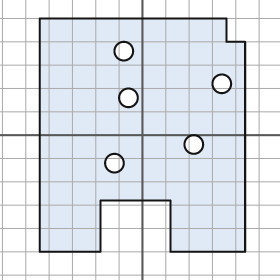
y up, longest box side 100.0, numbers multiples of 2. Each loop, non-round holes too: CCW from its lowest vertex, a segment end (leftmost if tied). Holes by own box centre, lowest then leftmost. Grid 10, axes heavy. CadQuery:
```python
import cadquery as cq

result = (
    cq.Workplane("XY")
    .moveTo(-44.0, -50.0)
    .lineTo(-18.0, -50.0)
    .lineTo(-18.0, -28.0)
    .lineTo(12.0, -28.0)
    .lineTo(12.0, -50.0)
    .lineTo(44.0, -50.0)
    .lineTo(44.0, 40.0)
    .lineTo(36.0, 40.0)
    .lineTo(36.0, 50.0)
    .lineTo(-44.0, 50.0)
    .close()
    .moveTo(-12.0, -12.0)
    .circle(4.0)
    .moveTo(22.0, -4.0)
    .circle(4.0)
    .moveTo(-6.0, 16.0)
    .circle(4.0)
    .moveTo(34.0, 22.0)
    .circle(4.0)
    .moveTo(-8.0, 36.0)
    .circle(4.0)
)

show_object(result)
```